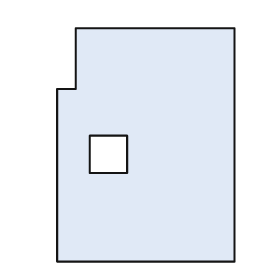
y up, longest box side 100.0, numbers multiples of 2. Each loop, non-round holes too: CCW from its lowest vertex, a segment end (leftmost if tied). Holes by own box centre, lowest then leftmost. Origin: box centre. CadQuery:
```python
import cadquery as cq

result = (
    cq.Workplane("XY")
    .moveTo(-38.0, -50.0)
    .lineTo(38.0, -50.0)
    .lineTo(38.0, 50.0)
    .lineTo(-30.0, 50.0)
    .lineTo(-30.0, 24.0)
    .lineTo(-38.0, 24.0)
    .close()
    .moveTo(-24.0, -12.0)
    .lineTo(-8.0, -12.0)
    .lineTo(-8.0, 4.0)
    .lineTo(-24.0, 4.0)
    .close()
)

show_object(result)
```